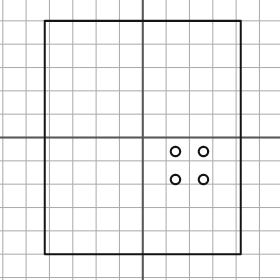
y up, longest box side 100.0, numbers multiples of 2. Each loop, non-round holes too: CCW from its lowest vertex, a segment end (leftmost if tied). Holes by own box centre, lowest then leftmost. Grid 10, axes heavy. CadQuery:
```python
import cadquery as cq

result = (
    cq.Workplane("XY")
    .moveTo(-42.0, -50.0)
    .lineTo(42.0, -50.0)
    .lineTo(42.0, 50.0)
    .lineTo(-42.0, 50.0)
    .close()
    .moveTo(14.0, -18.0)
    .circle(2.0)
    .moveTo(26.0, -18.0)
    .circle(2.0)
    .moveTo(14.0, -6.0)
    .circle(2.0)
    .moveTo(26.0, -6.0)
    .circle(2.0)
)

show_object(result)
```